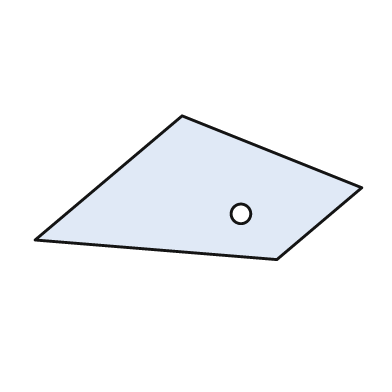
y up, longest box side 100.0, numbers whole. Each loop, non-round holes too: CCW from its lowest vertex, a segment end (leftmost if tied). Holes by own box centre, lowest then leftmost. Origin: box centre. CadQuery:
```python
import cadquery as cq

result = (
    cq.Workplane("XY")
    .moveTo(24.0, -22.0)
    .lineTo(50.0, 0.0)
    .lineTo(-5.0, 22.0)
    .lineTo(-50.0, -16.0)
    .close()
    .moveTo(13.0, -8.0)
    .circle(3.0)
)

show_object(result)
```